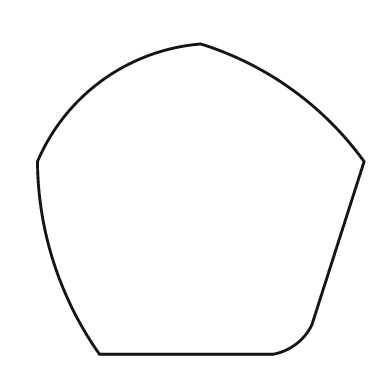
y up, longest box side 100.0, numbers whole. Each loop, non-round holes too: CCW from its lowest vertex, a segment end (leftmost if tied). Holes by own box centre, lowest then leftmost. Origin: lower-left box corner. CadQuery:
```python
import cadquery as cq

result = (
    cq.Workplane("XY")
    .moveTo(19.0, 0.0)
    .lineTo(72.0, 0.0)
    .threePointArc((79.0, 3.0), (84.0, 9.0))
    .lineTo(100.0, 59.0)
    .threePointArc((78.0, 81.0), (50.0, 95.0))
    .threePointArc((20.0, 84.0), (0.0, 59.0))
    .threePointArc((5.0, 28.0), (19.0, 0.0))
    .close()
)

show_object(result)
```